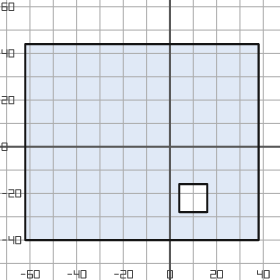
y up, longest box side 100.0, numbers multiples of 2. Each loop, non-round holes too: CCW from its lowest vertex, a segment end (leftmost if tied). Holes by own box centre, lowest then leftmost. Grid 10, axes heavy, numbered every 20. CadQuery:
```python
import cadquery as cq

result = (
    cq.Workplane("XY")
    .moveTo(-62.0, -40.0)
    .lineTo(38.0, -40.0)
    .lineTo(38.0, 44.0)
    .lineTo(-62.0, 44.0)
    .close()
    .moveTo(4.0, -28.0)
    .lineTo(16.0, -28.0)
    .lineTo(16.0, -16.0)
    .lineTo(4.0, -16.0)
    .close()
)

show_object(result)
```